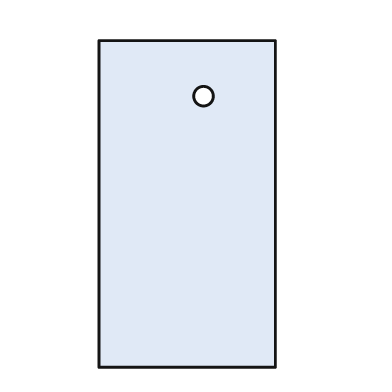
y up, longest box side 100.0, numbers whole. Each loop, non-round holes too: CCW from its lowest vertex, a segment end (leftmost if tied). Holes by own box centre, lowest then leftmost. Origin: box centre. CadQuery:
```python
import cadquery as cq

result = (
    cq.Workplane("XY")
    .moveTo(-27.0, -50.0)
    .lineTo(27.0, -50.0)
    .lineTo(27.0, 50.0)
    .lineTo(-27.0, 50.0)
    .close()
    .moveTo(5.0, 33.0)
    .circle(3.0)
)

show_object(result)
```